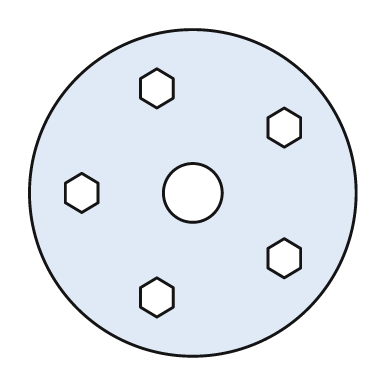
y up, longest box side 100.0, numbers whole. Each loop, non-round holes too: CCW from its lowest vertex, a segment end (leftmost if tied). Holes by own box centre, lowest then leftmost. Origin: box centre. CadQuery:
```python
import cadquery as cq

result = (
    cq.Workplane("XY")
    .moveTo(0.0, 0.0)
    .circle(50.0)
    .moveTo(-11.0, -38.0)
    .lineTo(-6.0, -35.0)
    .lineTo(-6.0, -29.0)
    .lineTo(-11.0, -26.0)
    .lineTo(-16.0, -29.0)
    .lineTo(-16.0, -35.0)
    .close()
    .moveTo(28.0, -26.0)
    .lineTo(33.0, -23.0)
    .lineTo(33.0, -17.0)
    .lineTo(28.0, -14.0)
    .lineTo(23.0, -17.0)
    .lineTo(23.0, -23.0)
    .close()
    .moveTo(-34.0, -6.0)
    .lineTo(-29.0, -3.0)
    .lineTo(-29.0, 3.0)
    .lineTo(-34.0, 6.0)
    .lineTo(-39.0, 3.0)
    .lineTo(-39.0, -3.0)
    .close()
    .moveTo(0.0, 0.0)
    .circle(9.0)
    .moveTo(28.0, 14.0)
    .lineTo(33.0, 17.0)
    .lineTo(33.0, 23.0)
    .lineTo(28.0, 26.0)
    .lineTo(23.0, 23.0)
    .lineTo(23.0, 17.0)
    .close()
    .moveTo(-11.0, 26.0)
    .lineTo(-6.0, 29.0)
    .lineTo(-6.0, 35.0)
    .lineTo(-11.0, 38.0)
    .lineTo(-16.0, 35.0)
    .lineTo(-16.0, 29.0)
    .close()
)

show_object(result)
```